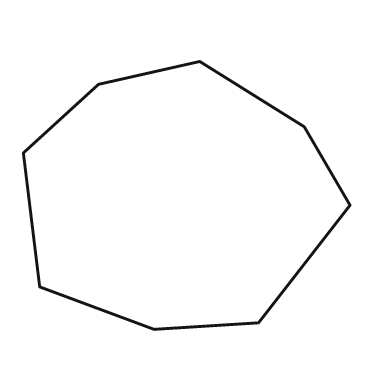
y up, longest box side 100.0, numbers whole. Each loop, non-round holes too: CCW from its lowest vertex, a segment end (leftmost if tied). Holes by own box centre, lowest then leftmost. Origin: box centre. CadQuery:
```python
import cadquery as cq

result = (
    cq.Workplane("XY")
    .moveTo(-10.0, -41.0)
    .lineTo(22.0, -39.0)
    .lineTo(50.0, -3.0)
    .lineTo(36.0, 21.0)
    .lineTo(4.0, 41.0)
    .lineTo(-27.0, 34.0)
    .lineTo(-50.0, 13.0)
    .lineTo(-45.0, -28.0)
    .close()
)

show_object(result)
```